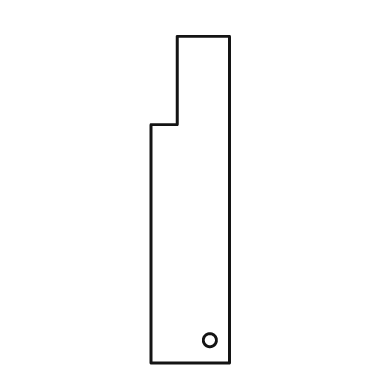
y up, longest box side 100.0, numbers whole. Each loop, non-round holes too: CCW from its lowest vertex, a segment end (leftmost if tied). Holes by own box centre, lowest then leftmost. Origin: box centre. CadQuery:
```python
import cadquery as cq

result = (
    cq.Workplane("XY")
    .moveTo(-12.0, -50.0)
    .lineTo(12.0, -50.0)
    .lineTo(12.0, 50.0)
    .lineTo(-4.0, 50.0)
    .lineTo(-4.0, 23.0)
    .lineTo(-12.0, 23.0)
    .close()
    .moveTo(6.0, -43.0)
    .circle(2.0)
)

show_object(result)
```